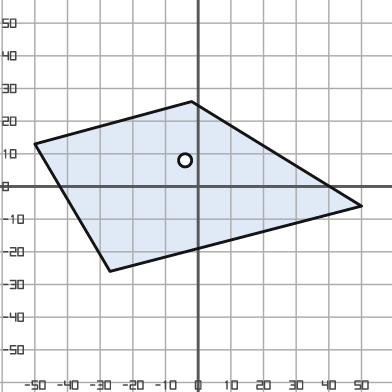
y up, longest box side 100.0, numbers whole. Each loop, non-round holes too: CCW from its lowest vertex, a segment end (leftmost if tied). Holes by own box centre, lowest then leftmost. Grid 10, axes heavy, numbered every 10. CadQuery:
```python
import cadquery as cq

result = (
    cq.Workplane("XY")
    .moveTo(-27.0, -26.0)
    .lineTo(50.0, -6.0)
    .lineTo(-2.0, 26.0)
    .lineTo(-50.0, 13.0)
    .close()
    .moveTo(-4.0, 8.0)
    .circle(2.0)
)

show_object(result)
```